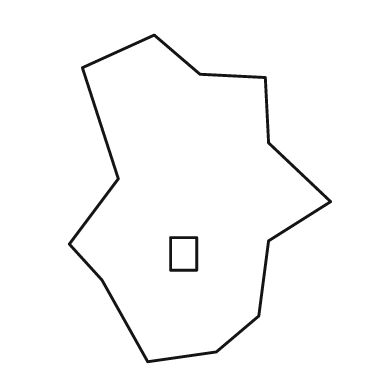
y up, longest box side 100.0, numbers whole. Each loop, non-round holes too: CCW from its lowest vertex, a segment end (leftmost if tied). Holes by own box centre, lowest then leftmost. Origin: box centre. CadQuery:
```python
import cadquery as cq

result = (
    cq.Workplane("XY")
    .moveTo(-16.0, -50.0)
    .lineTo(5.0, -47.0)
    .lineTo(18.0, -36.0)
    .lineTo(21.0, -13.0)
    .lineTo(40.0, -1.0)
    .lineTo(21.0, 17.0)
    .lineTo(20.0, 37.0)
    .lineTo(0.0, 38.0)
    .lineTo(-14.0, 50.0)
    .lineTo(-36.0, 40.0)
    .lineTo(-25.0, 6.0)
    .lineTo(-40.0, -14.0)
    .lineTo(-30.0, -25.0)
    .close()
    .moveTo(-9.0, -22.0)
    .lineTo(-1.0, -22.0)
    .lineTo(-1.0, -12.0)
    .lineTo(-9.0, -12.0)
    .close()
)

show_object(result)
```